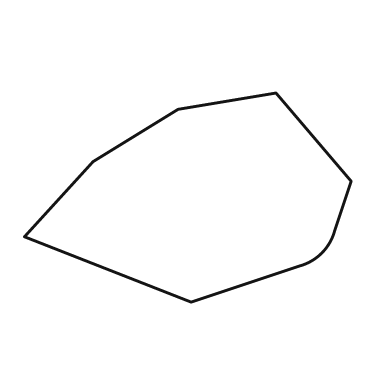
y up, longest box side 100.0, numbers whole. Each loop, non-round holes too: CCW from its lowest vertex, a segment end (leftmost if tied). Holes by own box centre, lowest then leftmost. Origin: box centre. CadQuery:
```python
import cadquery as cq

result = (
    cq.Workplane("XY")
    .moveTo(1.0, -32.0)
    .lineTo(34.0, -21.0)
    .threePointArc((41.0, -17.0), (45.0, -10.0))
    .lineTo(50.0, 5.0)
    .lineTo(27.0, 32.0)
    .lineTo(-3.0, 27.0)
    .lineTo(-29.0, 11.0)
    .lineTo(-50.0, -12.0)
    .close()
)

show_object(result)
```